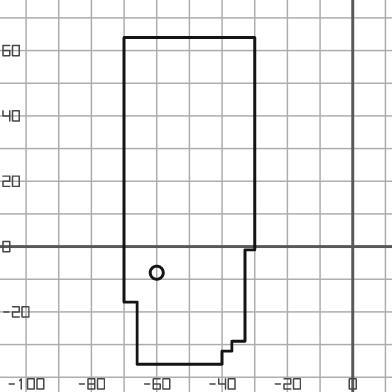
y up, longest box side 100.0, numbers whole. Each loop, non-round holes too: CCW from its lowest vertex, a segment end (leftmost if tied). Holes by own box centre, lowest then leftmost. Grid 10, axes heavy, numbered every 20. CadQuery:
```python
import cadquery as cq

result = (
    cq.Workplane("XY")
    .moveTo(-66.0, -36.0)
    .lineTo(-40.0, -36.0)
    .lineTo(-40.0, -32.0)
    .lineTo(-37.0, -32.0)
    .lineTo(-37.0, -29.0)
    .lineTo(-33.0, -29.0)
    .lineTo(-33.0, -1.0)
    .lineTo(-30.0, -1.0)
    .lineTo(-30.0, 64.0)
    .lineTo(-70.0, 64.0)
    .lineTo(-70.0, -17.0)
    .lineTo(-66.0, -17.0)
    .close()
    .moveTo(-60.0, -8.0)
    .circle(2.0)
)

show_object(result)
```